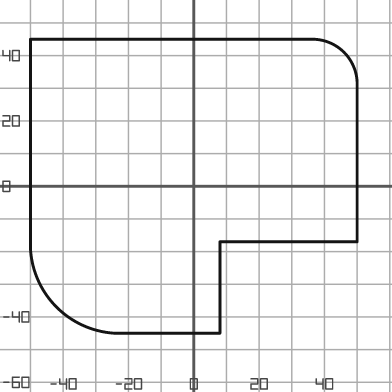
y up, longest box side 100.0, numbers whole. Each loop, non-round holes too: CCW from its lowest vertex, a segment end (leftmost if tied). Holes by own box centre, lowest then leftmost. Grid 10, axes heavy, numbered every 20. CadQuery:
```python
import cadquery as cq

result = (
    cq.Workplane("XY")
    .moveTo(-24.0, -45.0)
    .lineTo(8.0, -45.0)
    .lineTo(8.0, -17.0)
    .lineTo(50.0, -17.0)
    .lineTo(50.0, 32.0)
    .threePointArc((46.0, 41.0), (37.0, 45.0))
    .lineTo(-50.0, 45.0)
    .lineTo(-50.0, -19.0)
    .threePointArc((-42.0, -37.0), (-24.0, -45.0))
    .close()
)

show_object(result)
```